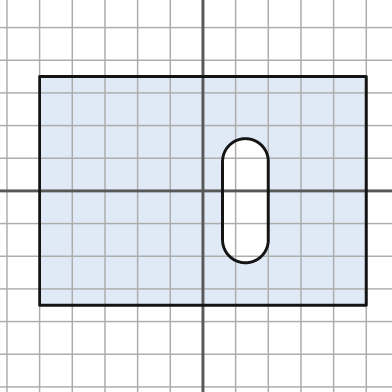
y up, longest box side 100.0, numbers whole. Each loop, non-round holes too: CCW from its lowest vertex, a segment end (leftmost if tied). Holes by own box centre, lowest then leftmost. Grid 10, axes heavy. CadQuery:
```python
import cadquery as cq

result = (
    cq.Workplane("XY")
    .moveTo(-50.0, -35.0)
    .lineTo(50.0, -35.0)
    .lineTo(50.0, 35.0)
    .lineTo(-50.0, 35.0)
    .close()
    .moveTo(6.0, -15.0)
    .threePointArc((13.0, -22.0), (20.0, -15.0))
    .lineTo(20.0, 9.0)
    .threePointArc((13.0, 16.0), (6.0, 9.0))
    .close()
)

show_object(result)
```